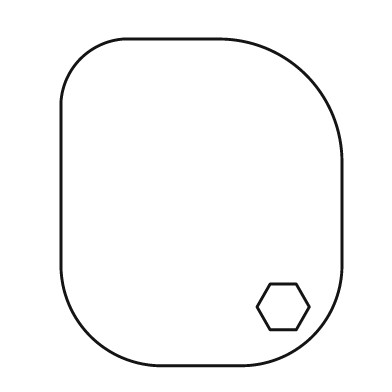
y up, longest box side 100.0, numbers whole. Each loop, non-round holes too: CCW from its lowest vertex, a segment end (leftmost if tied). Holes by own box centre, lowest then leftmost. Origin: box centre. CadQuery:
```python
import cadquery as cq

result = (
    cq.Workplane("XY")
    .moveTo(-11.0, -50.0)
    .lineTo(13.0, -50.0)
    .threePointArc((34.0, -41.0), (43.0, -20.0))
    .lineTo(43.0, 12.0)
    .threePointArc((32.0, 39.0), (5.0, 50.0))
    .lineTo(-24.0, 50.0)
    .threePointArc((-37.0, 44.0), (-43.0, 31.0))
    .lineTo(-43.0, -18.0)
    .threePointArc((-34.0, -41.0), (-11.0, -50.0))
    .close()
    .moveTo(21.0, -39.0)
    .lineTo(29.0, -39.0)
    .lineTo(33.0, -32.0)
    .lineTo(29.0, -25.0)
    .lineTo(21.0, -25.0)
    .lineTo(17.0, -32.0)
    .close()
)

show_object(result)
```